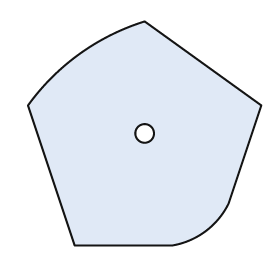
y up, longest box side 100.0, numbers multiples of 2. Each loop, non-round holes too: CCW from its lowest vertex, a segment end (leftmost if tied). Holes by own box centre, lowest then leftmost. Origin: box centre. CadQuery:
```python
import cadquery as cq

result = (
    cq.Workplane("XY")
    .moveTo(-30.0, -48.0)
    .lineTo(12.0, -48.0)
    .threePointArc((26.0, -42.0), (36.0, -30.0))
    .lineTo(50.0, 12.0)
    .lineTo(0.0, 48.0)
    .threePointArc((-28.0, 34.0), (-50.0, 12.0))
    .close()
    .moveTo(0.0, 0.0)
    .circle(4.0)
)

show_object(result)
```